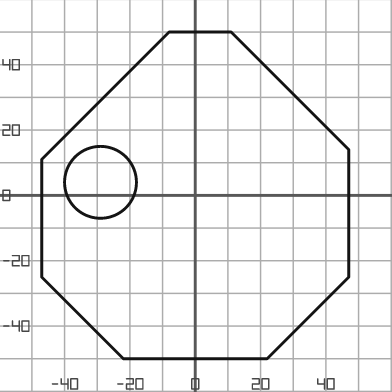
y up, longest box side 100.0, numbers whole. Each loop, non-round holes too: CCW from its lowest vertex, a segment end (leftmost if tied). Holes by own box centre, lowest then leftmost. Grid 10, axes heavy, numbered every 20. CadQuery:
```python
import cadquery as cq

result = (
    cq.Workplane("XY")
    .moveTo(-22.0, -50.0)
    .lineTo(22.0, -50.0)
    .lineTo(47.0, -25.0)
    .lineTo(47.0, 14.0)
    .lineTo(11.0, 50.0)
    .lineTo(-8.0, 50.0)
    .lineTo(-47.0, 11.0)
    .lineTo(-47.0, -25.0)
    .close()
    .moveTo(-29.0, 4.0)
    .circle(11.0)
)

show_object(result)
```